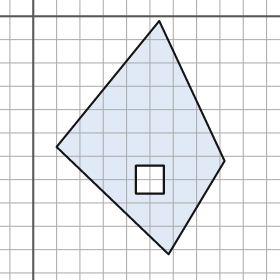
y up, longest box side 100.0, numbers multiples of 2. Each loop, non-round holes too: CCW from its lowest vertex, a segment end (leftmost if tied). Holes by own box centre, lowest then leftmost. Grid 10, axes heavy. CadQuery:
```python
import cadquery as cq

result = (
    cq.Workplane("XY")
    .moveTo(58.0, -102.0)
    .lineTo(82.0, -62.0)
    .lineTo(54.0, -2.0)
    .lineTo(10.0, -56.0)
    .close()
    .moveTo(44.0, -76.0)
    .lineTo(56.0, -76.0)
    .lineTo(56.0, -64.0)
    .lineTo(44.0, -64.0)
    .close()
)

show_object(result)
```